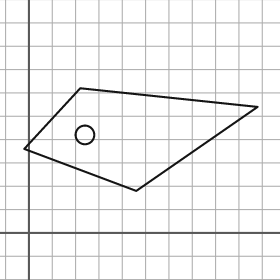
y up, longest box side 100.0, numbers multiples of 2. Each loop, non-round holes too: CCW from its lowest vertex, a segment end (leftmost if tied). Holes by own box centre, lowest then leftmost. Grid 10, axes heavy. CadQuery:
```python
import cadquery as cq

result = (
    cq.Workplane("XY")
    .moveTo(46.0, 18.0)
    .lineTo(98.0, 54.0)
    .lineTo(22.0, 62.0)
    .lineTo(-2.0, 36.0)
    .close()
    .moveTo(24.0, 42.0)
    .circle(4.0)
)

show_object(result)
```